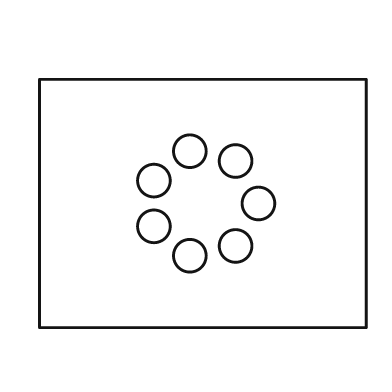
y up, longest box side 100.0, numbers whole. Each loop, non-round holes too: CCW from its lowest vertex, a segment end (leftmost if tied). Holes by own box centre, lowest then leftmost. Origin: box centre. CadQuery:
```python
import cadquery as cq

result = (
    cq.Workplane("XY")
    .moveTo(-50.0, -38.0)
    .lineTo(50.0, -38.0)
    .lineTo(50.0, 38.0)
    .lineTo(-50.0, 38.0)
    .close()
    .moveTo(-4.0, -16.0)
    .circle(5.0)
    .moveTo(10.0, -13.0)
    .circle(5.0)
    .moveTo(-15.0, -7.0)
    .circle(5.0)
    .moveTo(17.0, 0.0)
    .circle(5.0)
    .moveTo(-15.0, 7.0)
    .circle(5.0)
    .moveTo(10.0, 13.0)
    .circle(5.0)
    .moveTo(-4.0, 16.0)
    .circle(5.0)
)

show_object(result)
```